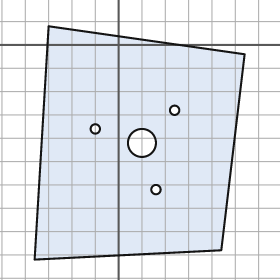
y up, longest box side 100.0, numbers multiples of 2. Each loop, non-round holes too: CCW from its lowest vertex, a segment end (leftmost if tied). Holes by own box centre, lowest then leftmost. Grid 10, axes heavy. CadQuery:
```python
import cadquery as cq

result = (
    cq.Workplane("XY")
    .moveTo(-36.0, -92.0)
    .lineTo(44.0, -88.0)
    .lineTo(54.0, -4.0)
    .lineTo(-30.0, 8.0)
    .close()
    .moveTo(16.0, -62.0)
    .circle(2.0)
    .moveTo(10.0, -42.0)
    .circle(6.0)
    .moveTo(-10.0, -36.0)
    .circle(2.0)
    .moveTo(24.0, -28.0)
    .circle(2.0)
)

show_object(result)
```